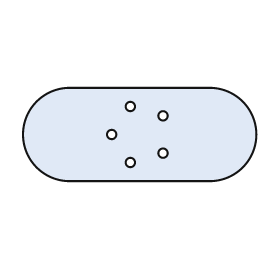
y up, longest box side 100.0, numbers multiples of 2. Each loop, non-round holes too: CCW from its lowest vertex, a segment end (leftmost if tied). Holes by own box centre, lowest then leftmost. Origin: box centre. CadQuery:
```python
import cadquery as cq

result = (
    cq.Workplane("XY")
    .moveTo(-30.0, -20.0)
    .lineTo(30.0, -20.0)
    .threePointArc((50.0, 0.0), (30.0, 20.0))
    .lineTo(-30.0, 20.0)
    .threePointArc((-50.0, 0.0), (-30.0, -20.0))
    .close()
    .moveTo(-4.0, -12.0)
    .circle(2.0)
    .moveTo(10.0, -8.0)
    .circle(2.0)
    .moveTo(-12.0, 0.0)
    .circle(2.0)
    .moveTo(10.0, 8.0)
    .circle(2.0)
    .moveTo(-4.0, 12.0)
    .circle(2.0)
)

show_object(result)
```